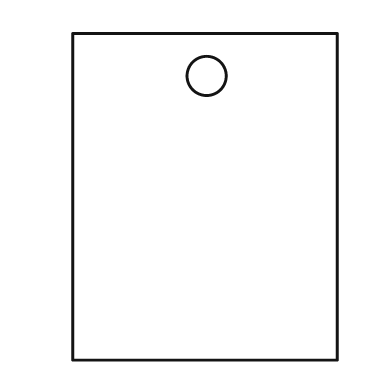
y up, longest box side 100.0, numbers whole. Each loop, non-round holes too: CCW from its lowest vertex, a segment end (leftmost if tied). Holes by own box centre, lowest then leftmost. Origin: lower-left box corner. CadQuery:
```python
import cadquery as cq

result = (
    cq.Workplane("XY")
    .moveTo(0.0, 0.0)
    .lineTo(81.0, 0.0)
    .lineTo(81.0, 100.0)
    .lineTo(0.0, 100.0)
    .close()
    .moveTo(41.0, 87.0)
    .circle(6.0)
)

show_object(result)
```